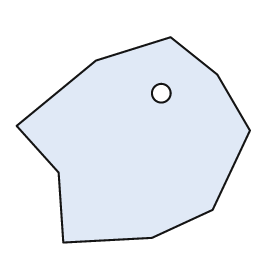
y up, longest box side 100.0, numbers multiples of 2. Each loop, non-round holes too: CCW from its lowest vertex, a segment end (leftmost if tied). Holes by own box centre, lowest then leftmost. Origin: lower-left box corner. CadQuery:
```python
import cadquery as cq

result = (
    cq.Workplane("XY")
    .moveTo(20.0, 0.0)
    .lineTo(58.0, 2.0)
    .lineTo(84.0, 14.0)
    .lineTo(100.0, 48.0)
    .lineTo(86.0, 72.0)
    .lineTo(66.0, 88.0)
    .lineTo(34.0, 78.0)
    .lineTo(0.0, 50.0)
    .lineTo(18.0, 30.0)
    .close()
    .moveTo(62.0, 64.0)
    .circle(4.0)
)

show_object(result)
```